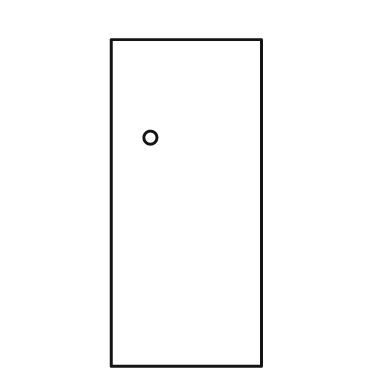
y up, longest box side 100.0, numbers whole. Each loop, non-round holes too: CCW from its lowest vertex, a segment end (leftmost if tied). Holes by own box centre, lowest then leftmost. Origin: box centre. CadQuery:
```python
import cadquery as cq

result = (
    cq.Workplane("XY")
    .moveTo(-23.0, -50.0)
    .lineTo(23.0, -50.0)
    .lineTo(23.0, 50.0)
    .lineTo(-23.0, 50.0)
    .close()
    .moveTo(-11.0, 20.0)
    .circle(2.0)
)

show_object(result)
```